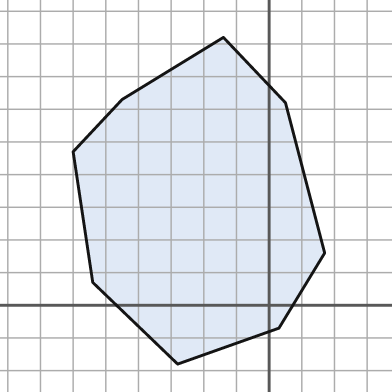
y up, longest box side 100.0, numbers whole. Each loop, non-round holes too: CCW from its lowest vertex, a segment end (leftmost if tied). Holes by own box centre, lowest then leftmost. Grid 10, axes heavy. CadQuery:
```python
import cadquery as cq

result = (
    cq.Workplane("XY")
    .moveTo(-28.0, -18.0)
    .lineTo(3.0, -7.0)
    .lineTo(17.0, 16.0)
    .lineTo(5.0, 62.0)
    .lineTo(-14.0, 82.0)
    .lineTo(-45.0, 63.0)
    .lineTo(-60.0, 47.0)
    .lineTo(-54.0, 7.0)
    .close()
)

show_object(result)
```